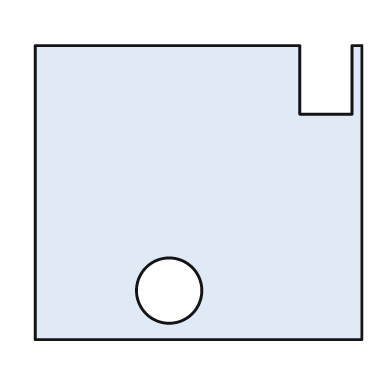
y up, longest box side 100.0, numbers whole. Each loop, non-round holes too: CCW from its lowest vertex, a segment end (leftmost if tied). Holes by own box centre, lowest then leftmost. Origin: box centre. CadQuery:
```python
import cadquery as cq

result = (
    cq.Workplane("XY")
    .moveTo(-50.0, -45.0)
    .lineTo(50.0, -45.0)
    .lineTo(50.0, 45.0)
    .lineTo(47.0, 45.0)
    .lineTo(47.0, 24.0)
    .lineTo(31.0, 24.0)
    .lineTo(31.0, 45.0)
    .lineTo(-50.0, 45.0)
    .close()
    .moveTo(-9.0, -30.0)
    .circle(10.0)
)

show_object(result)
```